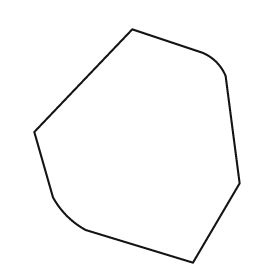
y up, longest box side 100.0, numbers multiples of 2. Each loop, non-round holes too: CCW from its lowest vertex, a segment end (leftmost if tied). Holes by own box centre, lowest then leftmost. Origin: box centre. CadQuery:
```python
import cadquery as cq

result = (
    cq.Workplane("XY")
    .moveTo(24.0, -50.0)
    .lineTo(44.0, -16.0)
    .lineTo(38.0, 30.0)
    .threePointArc((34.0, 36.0), (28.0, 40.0))
    .lineTo(-2.0, 50.0)
    .lineTo(-44.0, 6.0)
    .lineTo(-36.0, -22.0)
    .threePointArc((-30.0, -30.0), (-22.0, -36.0))
    .close()
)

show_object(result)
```